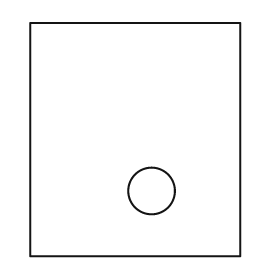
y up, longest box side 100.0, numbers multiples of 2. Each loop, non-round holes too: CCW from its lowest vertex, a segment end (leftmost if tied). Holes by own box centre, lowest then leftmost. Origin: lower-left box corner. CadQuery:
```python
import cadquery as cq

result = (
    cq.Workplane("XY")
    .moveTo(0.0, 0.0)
    .lineTo(90.0, 0.0)
    .lineTo(90.0, 100.0)
    .lineTo(0.0, 100.0)
    .close()
    .moveTo(52.0, 28.0)
    .circle(10.0)
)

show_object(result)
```